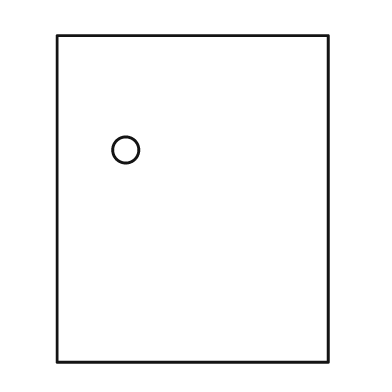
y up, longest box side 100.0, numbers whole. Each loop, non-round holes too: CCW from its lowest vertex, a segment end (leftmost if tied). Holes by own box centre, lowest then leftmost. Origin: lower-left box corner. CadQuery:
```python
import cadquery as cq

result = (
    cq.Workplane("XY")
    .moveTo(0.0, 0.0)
    .lineTo(83.0, 0.0)
    .lineTo(83.0, 100.0)
    .lineTo(0.0, 100.0)
    .close()
    .moveTo(21.0, 65.0)
    .circle(4.0)
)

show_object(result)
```